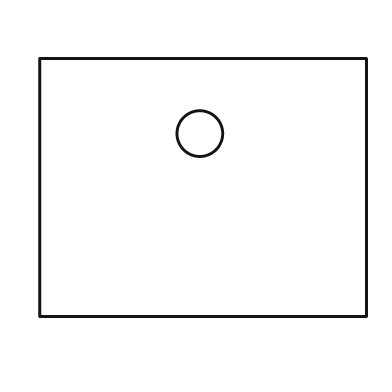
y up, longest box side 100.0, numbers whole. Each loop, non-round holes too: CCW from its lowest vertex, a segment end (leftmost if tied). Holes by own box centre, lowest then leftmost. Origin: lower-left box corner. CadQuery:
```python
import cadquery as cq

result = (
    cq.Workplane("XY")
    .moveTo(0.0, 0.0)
    .lineTo(100.0, 0.0)
    .lineTo(100.0, 79.0)
    .lineTo(0.0, 79.0)
    .close()
    .moveTo(49.0, 56.0)
    .circle(7.0)
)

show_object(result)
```